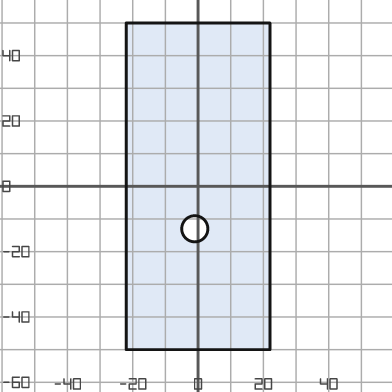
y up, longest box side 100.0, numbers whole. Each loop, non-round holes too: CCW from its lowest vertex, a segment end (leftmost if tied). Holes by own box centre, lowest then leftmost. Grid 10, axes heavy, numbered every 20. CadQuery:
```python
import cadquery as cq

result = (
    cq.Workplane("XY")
    .moveTo(-22.0, -50.0)
    .lineTo(22.0, -50.0)
    .lineTo(22.0, 50.0)
    .lineTo(-22.0, 50.0)
    .close()
    .moveTo(-1.0, -13.0)
    .circle(4.0)
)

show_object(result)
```